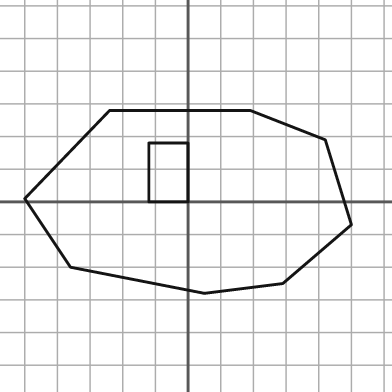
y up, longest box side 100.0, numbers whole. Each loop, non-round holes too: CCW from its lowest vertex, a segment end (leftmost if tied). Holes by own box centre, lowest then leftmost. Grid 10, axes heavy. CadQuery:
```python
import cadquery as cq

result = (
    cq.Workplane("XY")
    .moveTo(5.0, -28.0)
    .lineTo(29.0, -25.0)
    .lineTo(50.0, -7.0)
    .lineTo(42.0, 19.0)
    .lineTo(19.0, 28.0)
    .lineTo(-24.0, 28.0)
    .lineTo(-50.0, 1.0)
    .lineTo(-36.0, -20.0)
    .close()
    .moveTo(-12.0, 0.0)
    .lineTo(0.0, 0.0)
    .lineTo(0.0, 18.0)
    .lineTo(-12.0, 18.0)
    .close()
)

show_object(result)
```